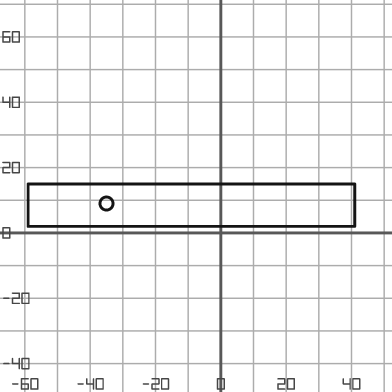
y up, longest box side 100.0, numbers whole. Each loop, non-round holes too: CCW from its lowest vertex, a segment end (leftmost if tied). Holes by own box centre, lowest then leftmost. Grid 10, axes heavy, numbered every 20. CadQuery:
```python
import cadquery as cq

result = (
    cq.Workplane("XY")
    .moveTo(-59.0, 2.0)
    .lineTo(41.0, 2.0)
    .lineTo(41.0, 15.0)
    .lineTo(-59.0, 15.0)
    .close()
    .moveTo(-35.0, 9.0)
    .circle(2.0)
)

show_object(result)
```